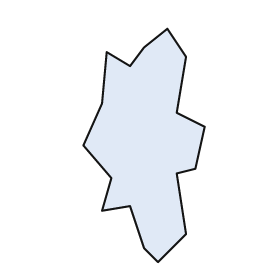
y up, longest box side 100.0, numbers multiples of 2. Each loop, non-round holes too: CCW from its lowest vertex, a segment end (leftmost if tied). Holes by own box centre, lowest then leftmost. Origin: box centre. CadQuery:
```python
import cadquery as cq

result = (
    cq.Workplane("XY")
    .moveTo(6.0, -50.0)
    .lineTo(18.0, -38.0)
    .lineTo(14.0, -12.0)
    .lineTo(22.0, -10.0)
    .lineTo(26.0, 8.0)
    .lineTo(14.0, 14.0)
    .lineTo(18.0, 38.0)
    .lineTo(10.0, 50.0)
    .lineTo(0.0, 42.0)
    .lineTo(-6.0, 34.0)
    .lineTo(-16.0, 40.0)
    .lineTo(-18.0, 18.0)
    .lineTo(-26.0, 0.0)
    .lineTo(-14.0, -14.0)
    .lineTo(-18.0, -28.0)
    .lineTo(-6.0, -26.0)
    .lineTo(0.0, -44.0)
    .close()
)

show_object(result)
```